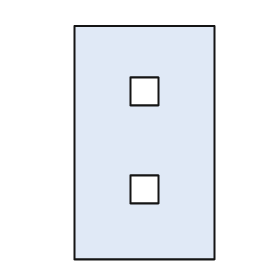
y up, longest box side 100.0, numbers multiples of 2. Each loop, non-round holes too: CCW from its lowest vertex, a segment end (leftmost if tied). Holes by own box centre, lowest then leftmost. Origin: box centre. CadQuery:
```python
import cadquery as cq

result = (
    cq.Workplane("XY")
    .moveTo(-30.0, -50.0)
    .lineTo(30.0, -50.0)
    .lineTo(30.0, 50.0)
    .lineTo(-30.0, 50.0)
    .close()
    .moveTo(-6.0, -26.0)
    .lineTo(6.0, -26.0)
    .lineTo(6.0, -14.0)
    .lineTo(-6.0, -14.0)
    .close()
    .moveTo(-6.0, 16.0)
    .lineTo(6.0, 16.0)
    .lineTo(6.0, 28.0)
    .lineTo(-6.0, 28.0)
    .close()
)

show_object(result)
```